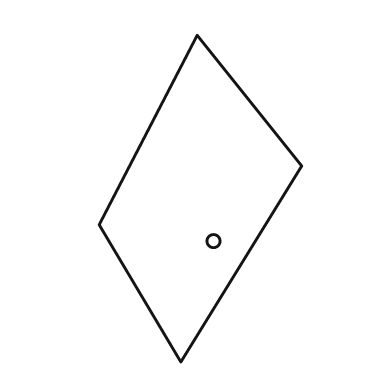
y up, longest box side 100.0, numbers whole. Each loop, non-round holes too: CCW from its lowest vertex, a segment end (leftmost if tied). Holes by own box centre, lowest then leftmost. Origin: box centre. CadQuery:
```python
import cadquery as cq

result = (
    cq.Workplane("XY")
    .moveTo(-6.0, -50.0)
    .lineTo(31.0, 10.0)
    .lineTo(-1.0, 50.0)
    .lineTo(-31.0, -8.0)
    .close()
    .moveTo(4.0, -13.0)
    .circle(2.0)
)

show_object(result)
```